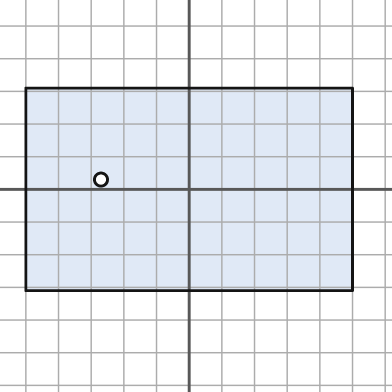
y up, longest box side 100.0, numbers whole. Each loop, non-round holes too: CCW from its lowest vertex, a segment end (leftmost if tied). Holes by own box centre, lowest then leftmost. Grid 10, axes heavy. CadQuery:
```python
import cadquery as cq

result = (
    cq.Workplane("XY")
    .moveTo(-50.0, -31.0)
    .lineTo(50.0, -31.0)
    .lineTo(50.0, 31.0)
    .lineTo(-50.0, 31.0)
    .close()
    .moveTo(-27.0, 3.0)
    .circle(2.0)
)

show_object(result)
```